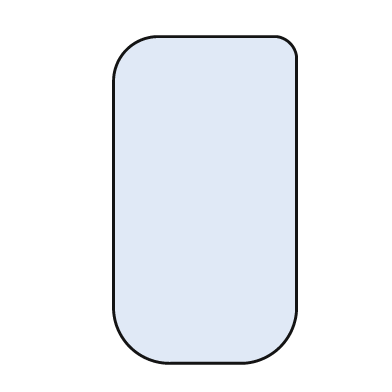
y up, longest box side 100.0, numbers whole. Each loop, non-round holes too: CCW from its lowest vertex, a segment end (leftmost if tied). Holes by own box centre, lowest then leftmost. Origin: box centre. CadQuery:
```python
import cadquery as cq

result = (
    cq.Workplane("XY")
    .moveTo(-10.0, -50.0)
    .lineTo(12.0, -50.0)
    .threePointArc((23.0, -45.0), (28.0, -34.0))
    .lineTo(28.0, 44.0)
    .threePointArc((26.0, 48.0), (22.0, 50.0))
    .lineTo(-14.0, 50.0)
    .threePointArc((-24.0, 46.0), (-28.0, 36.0))
    .lineTo(-28.0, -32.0)
    .threePointArc((-23.0, -45.0), (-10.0, -50.0))
    .close()
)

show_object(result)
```